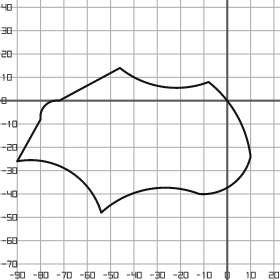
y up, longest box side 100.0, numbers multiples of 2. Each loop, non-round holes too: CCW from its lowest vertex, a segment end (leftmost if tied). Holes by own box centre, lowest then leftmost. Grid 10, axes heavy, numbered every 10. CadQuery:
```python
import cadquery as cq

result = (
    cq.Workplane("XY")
    .moveTo(-54.0, -48.0)
    .threePointArc((-34.0, -38.0), (-12.0, -40.0))
    .threePointArc((2.0, -36.0), (10.0, -24.0))
    .threePointArc((4.0, -6.0), (-8.0, 8.0))
    .threePointArc((-28.0, 6.0), (-46.0, 14.0))
    .lineTo(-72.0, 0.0)
    .threePointArc((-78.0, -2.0), (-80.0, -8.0))
    .lineTo(-90.0, -26.0)
    .threePointArc((-68.0, -30.0), (-54.0, -48.0))
    .close()
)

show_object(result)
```